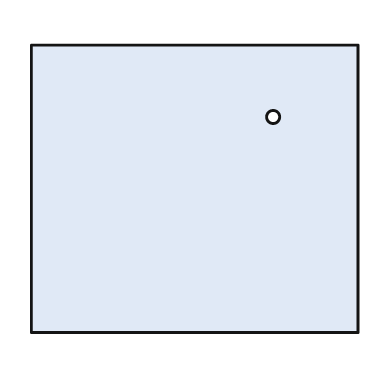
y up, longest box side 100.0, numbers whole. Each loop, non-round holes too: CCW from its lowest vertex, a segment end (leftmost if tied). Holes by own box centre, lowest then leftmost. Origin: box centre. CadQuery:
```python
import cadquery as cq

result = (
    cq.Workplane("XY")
    .moveTo(-50.0, -44.0)
    .lineTo(50.0, -44.0)
    .lineTo(50.0, 44.0)
    .lineTo(-50.0, 44.0)
    .close()
    .moveTo(24.0, 22.0)
    .circle(2.0)
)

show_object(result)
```